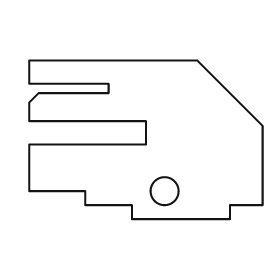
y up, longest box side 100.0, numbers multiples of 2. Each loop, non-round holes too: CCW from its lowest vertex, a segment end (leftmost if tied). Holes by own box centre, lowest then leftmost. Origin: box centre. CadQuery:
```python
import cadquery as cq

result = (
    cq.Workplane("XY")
    .moveTo(-6.0, -34.0)
    .lineTo(36.0, -34.0)
    .lineTo(36.0, -28.0)
    .lineTo(50.0, -28.0)
    .lineTo(50.0, 6.0)
    .lineTo(22.0, 34.0)
    .lineTo(-50.0, 34.0)
    .lineTo(-50.0, 24.0)
    .lineTo(-16.0, 24.0)
    .lineTo(-16.0, 20.0)
    .lineTo(-46.0, 20.0)
    .lineTo(-50.0, 16.0)
    .lineTo(-50.0, 8.0)
    .lineTo(0.0, 8.0)
    .lineTo(0.0, -2.0)
    .lineTo(-50.0, -2.0)
    .lineTo(-50.0, -22.0)
    .lineTo(-26.0, -22.0)
    .lineTo(-26.0, -28.0)
    .lineTo(-6.0, -28.0)
    .close()
    .moveTo(8.0, -22.0)
    .circle(6.0)
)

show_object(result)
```